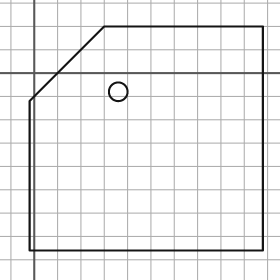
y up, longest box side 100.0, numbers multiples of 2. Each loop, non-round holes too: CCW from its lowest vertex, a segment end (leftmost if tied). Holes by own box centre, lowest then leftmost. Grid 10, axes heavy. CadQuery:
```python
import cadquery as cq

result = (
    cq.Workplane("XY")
    .moveTo(-2.0, -76.0)
    .lineTo(98.0, -76.0)
    .lineTo(98.0, 20.0)
    .lineTo(30.0, 20.0)
    .lineTo(-2.0, -12.0)
    .close()
    .moveTo(36.0, -8.0)
    .circle(4.0)
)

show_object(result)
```